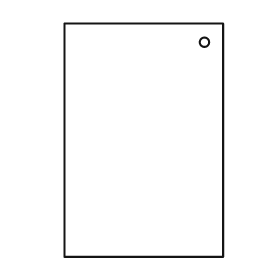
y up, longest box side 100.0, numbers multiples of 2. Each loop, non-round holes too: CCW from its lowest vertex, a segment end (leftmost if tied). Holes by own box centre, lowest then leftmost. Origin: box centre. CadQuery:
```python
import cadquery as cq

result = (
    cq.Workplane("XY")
    .moveTo(-34.0, -50.0)
    .lineTo(34.0, -50.0)
    .lineTo(34.0, 50.0)
    .lineTo(-34.0, 50.0)
    .close()
    .moveTo(26.0, 42.0)
    .circle(2.0)
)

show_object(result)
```